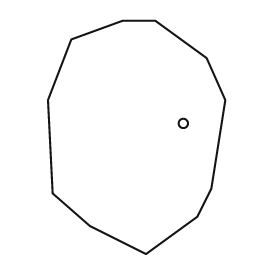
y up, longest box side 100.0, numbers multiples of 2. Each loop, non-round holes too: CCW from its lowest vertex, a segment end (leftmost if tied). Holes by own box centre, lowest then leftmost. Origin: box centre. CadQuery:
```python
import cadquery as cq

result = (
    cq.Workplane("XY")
    .moveTo(4.0, -50.0)
    .lineTo(26.0, -34.0)
    .lineTo(32.0, -22.0)
    .lineTo(38.0, 16.0)
    .lineTo(30.0, 34.0)
    .lineTo(8.0, 50.0)
    .lineTo(-6.0, 50.0)
    .lineTo(-28.0, 42.0)
    .lineTo(-38.0, 16.0)
    .lineTo(-36.0, -24.0)
    .lineTo(-20.0, -38.0)
    .close()
    .moveTo(20.0, 6.0)
    .circle(2.0)
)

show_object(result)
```